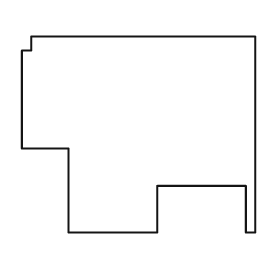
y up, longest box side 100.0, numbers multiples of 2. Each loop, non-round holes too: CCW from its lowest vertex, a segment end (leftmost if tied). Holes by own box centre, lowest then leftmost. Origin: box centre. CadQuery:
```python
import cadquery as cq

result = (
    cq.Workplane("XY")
    .moveTo(-30.0, -42.0)
    .lineTo(8.0, -42.0)
    .lineTo(8.0, -22.0)
    .lineTo(46.0, -22.0)
    .lineTo(46.0, -42.0)
    .lineTo(50.0, -42.0)
    .lineTo(50.0, 42.0)
    .lineTo(-46.0, 42.0)
    .lineTo(-46.0, 36.0)
    .lineTo(-50.0, 36.0)
    .lineTo(-50.0, -6.0)
    .lineTo(-30.0, -6.0)
    .close()
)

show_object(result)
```